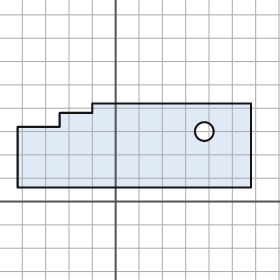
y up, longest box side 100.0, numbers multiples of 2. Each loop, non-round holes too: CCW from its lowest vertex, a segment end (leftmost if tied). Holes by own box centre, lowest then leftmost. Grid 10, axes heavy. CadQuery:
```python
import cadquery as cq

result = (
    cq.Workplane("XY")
    .moveTo(-42.0, 6.0)
    .lineTo(58.0, 6.0)
    .lineTo(58.0, 42.0)
    .lineTo(-10.0, 42.0)
    .lineTo(-10.0, 38.0)
    .lineTo(-24.0, 38.0)
    .lineTo(-24.0, 32.0)
    .lineTo(-42.0, 32.0)
    .close()
    .moveTo(38.0, 30.0)
    .circle(4.0)
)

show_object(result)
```